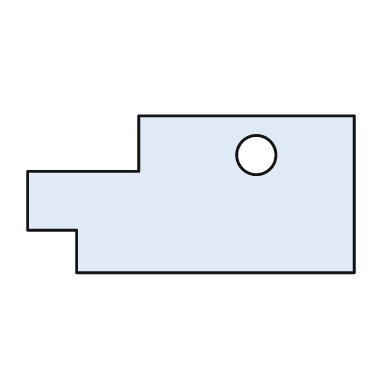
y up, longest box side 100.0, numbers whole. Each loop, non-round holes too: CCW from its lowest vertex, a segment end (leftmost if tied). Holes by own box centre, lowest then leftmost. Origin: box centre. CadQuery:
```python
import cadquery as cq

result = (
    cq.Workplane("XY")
    .moveTo(-35.0, -24.0)
    .lineTo(50.0, -24.0)
    .lineTo(50.0, 24.0)
    .lineTo(-16.0, 24.0)
    .lineTo(-16.0, 7.0)
    .lineTo(-50.0, 7.0)
    .lineTo(-50.0, -11.0)
    .lineTo(-35.0, -11.0)
    .close()
    .moveTo(20.0, 12.0)
    .circle(6.0)
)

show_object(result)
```